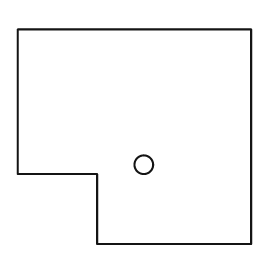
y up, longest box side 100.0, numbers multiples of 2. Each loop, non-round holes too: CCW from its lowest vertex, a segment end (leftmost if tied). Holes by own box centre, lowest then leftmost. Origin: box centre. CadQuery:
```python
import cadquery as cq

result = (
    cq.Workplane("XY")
    .moveTo(-16.0, -46.0)
    .lineTo(50.0, -46.0)
    .lineTo(50.0, 46.0)
    .lineTo(-50.0, 46.0)
    .lineTo(-50.0, -16.0)
    .lineTo(-16.0, -16.0)
    .close()
    .moveTo(4.0, -12.0)
    .circle(4.0)
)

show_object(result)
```